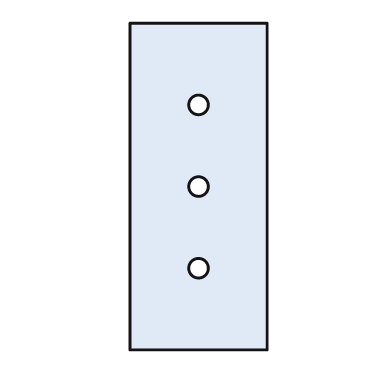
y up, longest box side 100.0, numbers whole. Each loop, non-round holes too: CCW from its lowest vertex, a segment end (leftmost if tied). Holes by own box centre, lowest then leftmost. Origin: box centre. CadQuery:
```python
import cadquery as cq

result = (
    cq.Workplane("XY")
    .moveTo(-21.0, -50.0)
    .lineTo(21.0, -50.0)
    .lineTo(21.0, 50.0)
    .lineTo(-21.0, 50.0)
    .close()
    .moveTo(0.0, -25.0)
    .circle(3.0)
    .moveTo(0.0, 0.0)
    .circle(3.0)
    .moveTo(0.0, 25.0)
    .circle(3.0)
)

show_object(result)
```